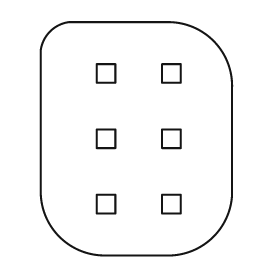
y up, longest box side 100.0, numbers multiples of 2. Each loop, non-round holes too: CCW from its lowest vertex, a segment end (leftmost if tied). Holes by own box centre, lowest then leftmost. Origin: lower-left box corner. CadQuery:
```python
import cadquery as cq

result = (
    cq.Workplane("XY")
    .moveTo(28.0, 0.0)
    .lineTo(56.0, 0.0)
    .threePointArc((74.0, 8.0), (82.0, 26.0))
    .lineTo(82.0, 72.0)
    .threePointArc((74.0, 92.0), (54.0, 100.0))
    .lineTo(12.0, 100.0)
    .threePointArc((4.0, 96.0), (0.0, 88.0))
    .lineTo(0.0, 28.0)
    .threePointArc((8.0, 8.0), (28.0, 0.0))
    .close()
    .moveTo(24.0, 18.0)
    .lineTo(32.0, 18.0)
    .lineTo(32.0, 26.0)
    .lineTo(24.0, 26.0)
    .close()
    .moveTo(52.0, 18.0)
    .lineTo(60.0, 18.0)
    .lineTo(60.0, 26.0)
    .lineTo(52.0, 26.0)
    .close()
    .moveTo(24.0, 46.0)
    .lineTo(32.0, 46.0)
    .lineTo(32.0, 54.0)
    .lineTo(24.0, 54.0)
    .close()
    .moveTo(52.0, 46.0)
    .lineTo(60.0, 46.0)
    .lineTo(60.0, 54.0)
    .lineTo(52.0, 54.0)
    .close()
    .moveTo(24.0, 74.0)
    .lineTo(32.0, 74.0)
    .lineTo(32.0, 82.0)
    .lineTo(24.0, 82.0)
    .close()
    .moveTo(52.0, 74.0)
    .lineTo(60.0, 74.0)
    .lineTo(60.0, 82.0)
    .lineTo(52.0, 82.0)
    .close()
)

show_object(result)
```